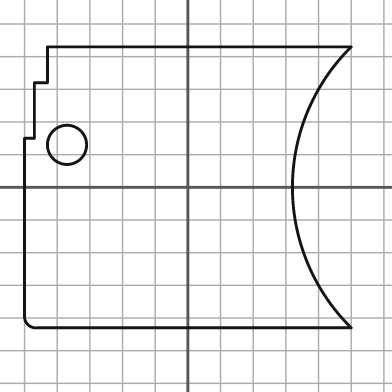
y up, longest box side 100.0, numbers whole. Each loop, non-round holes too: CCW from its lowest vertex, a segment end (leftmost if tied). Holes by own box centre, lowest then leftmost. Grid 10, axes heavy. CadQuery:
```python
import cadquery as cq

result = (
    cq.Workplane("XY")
    .moveTo(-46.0, -43.0)
    .lineTo(50.0, -43.0)
    .threePointArc((32.0, 0.0), (50.0, 43.0))
    .lineTo(-43.0, 43.0)
    .lineTo(-43.0, 32.0)
    .lineTo(-47.0, 32.0)
    .lineTo(-47.0, 15.0)
    .lineTo(-50.0, 15.0)
    .lineTo(-50.0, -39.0)
    .threePointArc((-49.0, -42.0), (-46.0, -43.0))
    .close()
    .moveTo(-37.0, 13.0)
    .circle(6.0)
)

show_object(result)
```